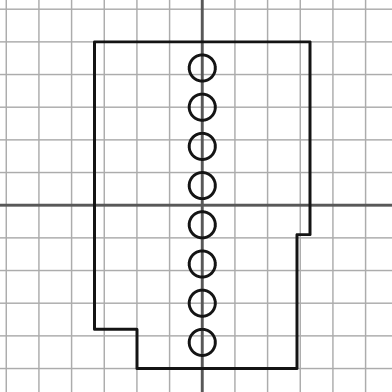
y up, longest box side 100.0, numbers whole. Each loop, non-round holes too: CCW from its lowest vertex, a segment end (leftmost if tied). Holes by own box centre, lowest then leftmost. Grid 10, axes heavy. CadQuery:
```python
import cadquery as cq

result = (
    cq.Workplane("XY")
    .moveTo(-20.0, -50.0)
    .lineTo(29.0, -50.0)
    .lineTo(29.0, -9.0)
    .lineTo(33.0, -9.0)
    .lineTo(33.0, 50.0)
    .lineTo(-33.0, 50.0)
    .lineTo(-33.0, -38.0)
    .lineTo(-20.0, -38.0)
    .close()
    .moveTo(0.0, -42.0)
    .circle(4.0)
    .moveTo(0.0, -30.0)
    .circle(4.0)
    .moveTo(0.0, -18.0)
    .circle(4.0)
    .moveTo(0.0, -6.0)
    .circle(4.0)
    .moveTo(0.0, 6.0)
    .circle(4.0)
    .moveTo(0.0, 18.0)
    .circle(4.0)
    .moveTo(0.0, 30.0)
    .circle(4.0)
    .moveTo(0.0, 42.0)
    .circle(4.0)
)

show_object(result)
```